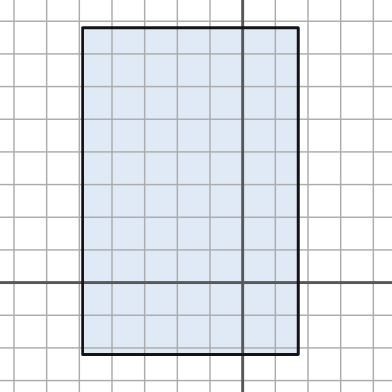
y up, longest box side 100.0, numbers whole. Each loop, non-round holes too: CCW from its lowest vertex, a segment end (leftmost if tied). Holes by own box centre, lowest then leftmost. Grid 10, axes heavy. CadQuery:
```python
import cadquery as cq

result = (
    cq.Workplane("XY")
    .moveTo(-49.0, -22.0)
    .lineTo(17.0, -22.0)
    .lineTo(17.0, 78.0)
    .lineTo(-49.0, 78.0)
    .close()
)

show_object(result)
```